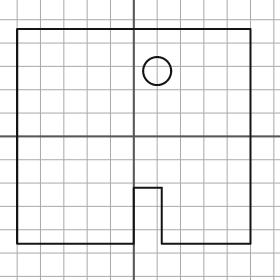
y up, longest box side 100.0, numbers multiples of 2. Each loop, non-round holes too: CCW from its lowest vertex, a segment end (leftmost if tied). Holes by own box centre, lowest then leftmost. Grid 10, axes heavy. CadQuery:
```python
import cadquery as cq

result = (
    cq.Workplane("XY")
    .moveTo(-50.0, -46.0)
    .lineTo(0.0, -46.0)
    .lineTo(0.0, -22.0)
    .lineTo(12.0, -22.0)
    .lineTo(12.0, -46.0)
    .lineTo(50.0, -46.0)
    .lineTo(50.0, 46.0)
    .lineTo(-50.0, 46.0)
    .close()
    .moveTo(10.0, 28.0)
    .circle(6.0)
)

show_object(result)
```